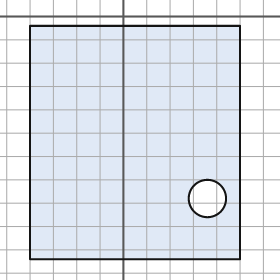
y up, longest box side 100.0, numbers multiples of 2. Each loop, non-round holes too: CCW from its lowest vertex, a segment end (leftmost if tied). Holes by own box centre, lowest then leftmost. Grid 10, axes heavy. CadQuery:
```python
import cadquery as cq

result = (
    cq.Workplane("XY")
    .moveTo(-40.0, -104.0)
    .lineTo(50.0, -104.0)
    .lineTo(50.0, -4.0)
    .lineTo(-40.0, -4.0)
    .close()
    .moveTo(36.0, -78.0)
    .circle(8.0)
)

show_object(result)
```